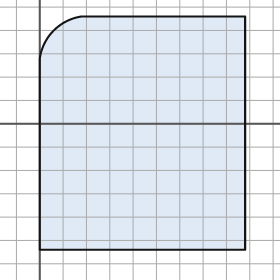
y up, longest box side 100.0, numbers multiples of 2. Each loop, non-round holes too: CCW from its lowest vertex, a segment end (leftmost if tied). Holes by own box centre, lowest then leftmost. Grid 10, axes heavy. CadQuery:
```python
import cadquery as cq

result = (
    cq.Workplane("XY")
    .moveTo(0.0, -54.0)
    .lineTo(88.0, -54.0)
    .lineTo(88.0, 46.0)
    .lineTo(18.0, 46.0)
    .threePointArc((6.0, 40.0), (0.0, 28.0))
    .close()
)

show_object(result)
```